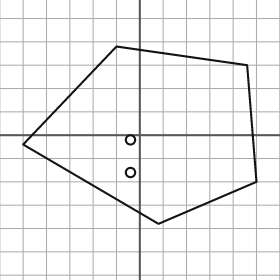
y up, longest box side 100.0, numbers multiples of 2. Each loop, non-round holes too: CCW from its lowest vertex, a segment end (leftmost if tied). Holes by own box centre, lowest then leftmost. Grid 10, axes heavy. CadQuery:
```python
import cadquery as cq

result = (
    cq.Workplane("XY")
    .moveTo(8.0, -38.0)
    .lineTo(50.0, -20.0)
    .lineTo(46.0, 30.0)
    .lineTo(-10.0, 38.0)
    .lineTo(-50.0, -4.0)
    .close()
    .moveTo(-4.0, -16.0)
    .circle(2.0)
    .moveTo(-4.0, -2.0)
    .circle(2.0)
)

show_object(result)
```